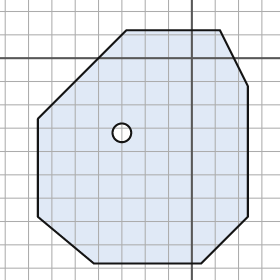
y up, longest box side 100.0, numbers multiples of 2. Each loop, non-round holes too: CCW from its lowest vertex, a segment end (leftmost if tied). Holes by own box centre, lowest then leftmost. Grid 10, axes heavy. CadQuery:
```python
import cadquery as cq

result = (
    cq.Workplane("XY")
    .moveTo(-42.0, -88.0)
    .lineTo(4.0, -88.0)
    .lineTo(24.0, -68.0)
    .lineTo(24.0, -12.0)
    .lineTo(12.0, 12.0)
    .lineTo(-28.0, 12.0)
    .lineTo(-66.0, -26.0)
    .lineTo(-66.0, -68.0)
    .close()
    .moveTo(-30.0, -32.0)
    .circle(4.0)
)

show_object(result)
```